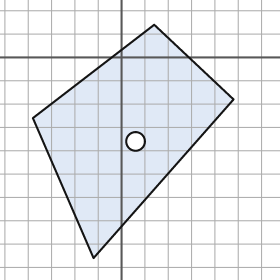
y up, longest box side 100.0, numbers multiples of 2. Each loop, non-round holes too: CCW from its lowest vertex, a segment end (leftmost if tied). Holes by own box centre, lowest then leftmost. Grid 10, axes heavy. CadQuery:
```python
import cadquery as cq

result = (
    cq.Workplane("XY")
    .moveTo(-12.0, -86.0)
    .lineTo(48.0, -18.0)
    .lineTo(14.0, 14.0)
    .lineTo(-38.0, -26.0)
    .close()
    .moveTo(6.0, -36.0)
    .circle(4.0)
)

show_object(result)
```